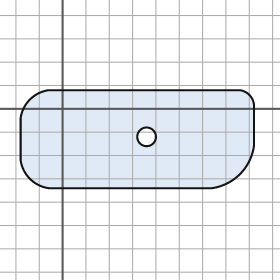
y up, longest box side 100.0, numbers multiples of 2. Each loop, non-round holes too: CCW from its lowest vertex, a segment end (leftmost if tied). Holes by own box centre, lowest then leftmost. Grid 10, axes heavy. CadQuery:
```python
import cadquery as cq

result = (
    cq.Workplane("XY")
    .moveTo(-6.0, -34.0)
    .lineTo(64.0, -34.0)
    .threePointArc((76.0, -28.0), (82.0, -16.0))
    .lineTo(82.0, 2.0)
    .threePointArc((80.0, 6.0), (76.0, 8.0))
    .lineTo(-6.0, 8.0)
    .threePointArc((-14.0, 4.0), (-18.0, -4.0))
    .lineTo(-18.0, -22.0)
    .threePointArc((-14.0, -30.0), (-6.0, -34.0))
    .close()
    .moveTo(36.0, -12.0)
    .circle(4.0)
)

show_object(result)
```